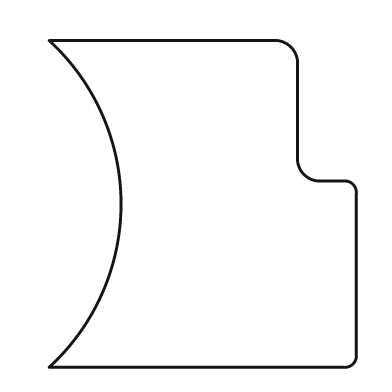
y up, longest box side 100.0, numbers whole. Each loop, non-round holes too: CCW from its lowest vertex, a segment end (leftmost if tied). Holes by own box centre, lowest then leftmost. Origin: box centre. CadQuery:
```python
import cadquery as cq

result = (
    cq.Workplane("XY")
    .moveTo(-47.0, -50.0)
    .lineTo(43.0, -50.0)
    .threePointArc((46.0, -49.0), (47.0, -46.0))
    .lineTo(47.0, 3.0)
    .threePointArc((46.0, 6.0), (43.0, 7.0))
    .lineTo(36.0, 7.0)
    .threePointArc((31.0, 9.0), (29.0, 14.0))
    .lineTo(29.0, 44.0)
    .threePointArc((27.0, 48.0), (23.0, 50.0))
    .lineTo(-47.0, 50.0)
    .threePointArc((-25.0, 0.0), (-47.0, -50.0))
    .close()
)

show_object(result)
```